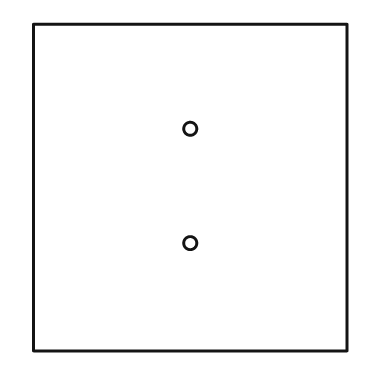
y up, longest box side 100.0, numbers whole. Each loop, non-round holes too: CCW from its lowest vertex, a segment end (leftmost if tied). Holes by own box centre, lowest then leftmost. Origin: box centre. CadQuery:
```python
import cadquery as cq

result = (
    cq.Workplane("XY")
    .moveTo(-48.0, -50.0)
    .lineTo(48.0, -50.0)
    .lineTo(48.0, 50.0)
    .lineTo(-48.0, 50.0)
    .close()
    .moveTo(0.0, -17.0)
    .circle(2.0)
    .moveTo(0.0, 18.0)
    .circle(2.0)
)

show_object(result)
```